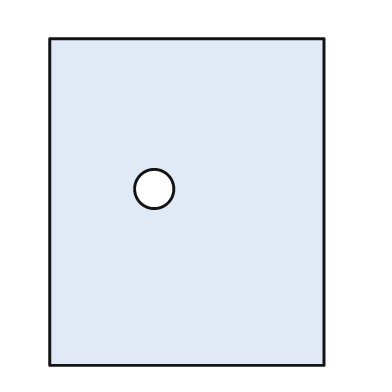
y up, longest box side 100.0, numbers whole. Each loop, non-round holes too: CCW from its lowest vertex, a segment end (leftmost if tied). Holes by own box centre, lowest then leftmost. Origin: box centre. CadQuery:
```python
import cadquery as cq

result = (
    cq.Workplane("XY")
    .moveTo(-42.0, -50.0)
    .lineTo(42.0, -50.0)
    .lineTo(42.0, 50.0)
    .lineTo(-42.0, 50.0)
    .close()
    .moveTo(-10.0, 4.0)
    .circle(6.0)
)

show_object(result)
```